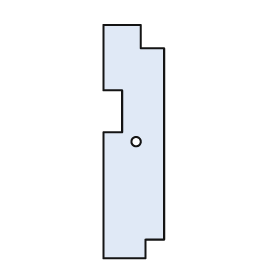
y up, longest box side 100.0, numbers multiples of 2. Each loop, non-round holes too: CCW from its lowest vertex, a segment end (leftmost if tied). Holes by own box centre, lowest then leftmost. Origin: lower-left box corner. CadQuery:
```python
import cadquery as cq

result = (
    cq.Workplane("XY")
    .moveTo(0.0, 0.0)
    .lineTo(18.0, 0.0)
    .lineTo(18.0, 8.0)
    .lineTo(26.0, 8.0)
    .lineTo(26.0, 90.0)
    .lineTo(16.0, 90.0)
    .lineTo(16.0, 100.0)
    .lineTo(0.0, 100.0)
    .lineTo(0.0, 72.0)
    .lineTo(8.0, 72.0)
    .lineTo(8.0, 54.0)
    .lineTo(0.0, 54.0)
    .close()
    .moveTo(14.0, 50.0)
    .circle(2.0)
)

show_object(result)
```